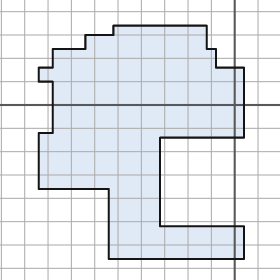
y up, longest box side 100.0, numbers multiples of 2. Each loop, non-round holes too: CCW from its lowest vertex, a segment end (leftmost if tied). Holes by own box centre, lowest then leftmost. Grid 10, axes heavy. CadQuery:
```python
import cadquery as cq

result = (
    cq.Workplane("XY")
    .moveTo(-54.0, -66.0)
    .lineTo(4.0, -66.0)
    .lineTo(4.0, -52.0)
    .lineTo(-32.0, -52.0)
    .lineTo(-32.0, -14.0)
    .lineTo(4.0, -14.0)
    .lineTo(4.0, 16.0)
    .lineTo(-8.0, 16.0)
    .lineTo(-8.0, 24.0)
    .lineTo(-12.0, 24.0)
    .lineTo(-12.0, 34.0)
    .lineTo(-52.0, 34.0)
    .lineTo(-52.0, 30.0)
    .lineTo(-64.0, 30.0)
    .lineTo(-64.0, 24.0)
    .lineTo(-78.0, 24.0)
    .lineTo(-78.0, 16.0)
    .lineTo(-84.0, 16.0)
    .lineTo(-84.0, 10.0)
    .lineTo(-78.0, 10.0)
    .lineTo(-78.0, -12.0)
    .lineTo(-84.0, -12.0)
    .lineTo(-84.0, -36.0)
    .lineTo(-54.0, -36.0)
    .close()
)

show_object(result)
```